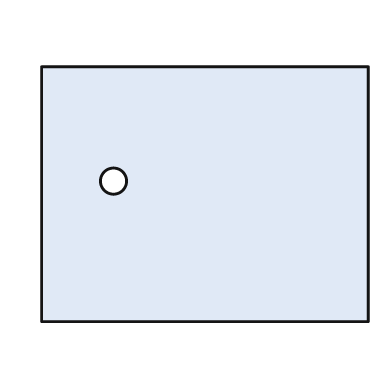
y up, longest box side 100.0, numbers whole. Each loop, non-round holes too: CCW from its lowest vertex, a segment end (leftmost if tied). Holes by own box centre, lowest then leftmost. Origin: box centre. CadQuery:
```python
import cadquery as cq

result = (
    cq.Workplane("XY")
    .moveTo(-50.0, -39.0)
    .lineTo(50.0, -39.0)
    .lineTo(50.0, 39.0)
    .lineTo(-50.0, 39.0)
    .close()
    .moveTo(-28.0, 4.0)
    .circle(4.0)
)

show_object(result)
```